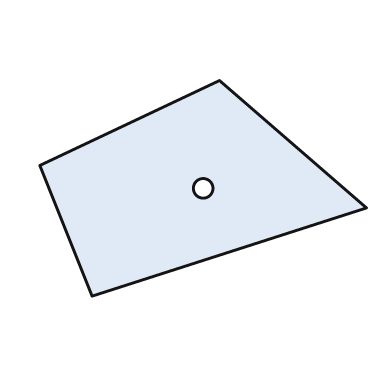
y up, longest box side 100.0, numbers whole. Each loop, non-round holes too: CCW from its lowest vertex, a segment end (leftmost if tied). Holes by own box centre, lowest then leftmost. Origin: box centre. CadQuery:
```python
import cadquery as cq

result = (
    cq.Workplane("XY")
    .moveTo(-34.0, -33.0)
    .lineTo(50.0, -6.0)
    .lineTo(5.0, 33.0)
    .lineTo(-50.0, 7.0)
    .close()
    .moveTo(0.0, 0.0)
    .circle(3.0)
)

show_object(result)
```